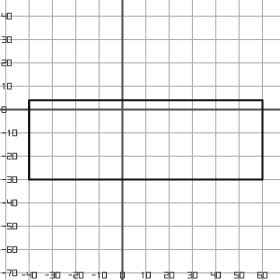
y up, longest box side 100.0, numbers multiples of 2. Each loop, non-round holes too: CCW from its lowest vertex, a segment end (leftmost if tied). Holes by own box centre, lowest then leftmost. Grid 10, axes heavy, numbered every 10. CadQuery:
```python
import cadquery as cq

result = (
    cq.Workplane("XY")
    .moveTo(-40.0, -30.0)
    .lineTo(60.0, -30.0)
    .lineTo(60.0, 4.0)
    .lineTo(-40.0, 4.0)
    .close()
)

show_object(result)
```